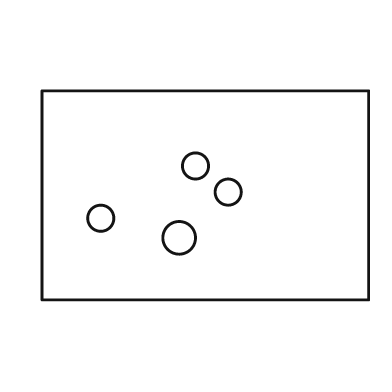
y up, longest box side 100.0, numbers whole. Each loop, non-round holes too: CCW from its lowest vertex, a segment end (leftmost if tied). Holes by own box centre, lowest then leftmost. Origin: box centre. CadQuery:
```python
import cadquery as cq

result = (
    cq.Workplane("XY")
    .moveTo(-50.0, -32.0)
    .lineTo(50.0, -32.0)
    .lineTo(50.0, 32.0)
    .lineTo(-50.0, 32.0)
    .close()
    .moveTo(-8.0, -13.0)
    .circle(5.0)
    .moveTo(-32.0, -7.0)
    .circle(4.0)
    .moveTo(7.0, 1.0)
    .circle(4.0)
    .moveTo(-3.0, 9.0)
    .circle(4.0)
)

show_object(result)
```